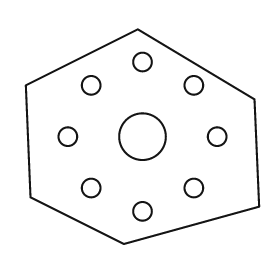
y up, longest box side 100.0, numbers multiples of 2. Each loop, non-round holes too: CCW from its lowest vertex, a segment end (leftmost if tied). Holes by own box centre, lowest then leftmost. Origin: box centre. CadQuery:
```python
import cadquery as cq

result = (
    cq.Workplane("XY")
    .moveTo(-8.0, -46.0)
    .lineTo(50.0, -30.0)
    .lineTo(48.0, 16.0)
    .lineTo(-2.0, 46.0)
    .lineTo(-50.0, 22.0)
    .lineTo(-48.0, -26.0)
    .close()
    .moveTo(0.0, -32.0)
    .circle(4.0)
    .moveTo(-22.0, -22.0)
    .circle(4.0)
    .moveTo(22.0, -22.0)
    .circle(4.0)
    .moveTo(-32.0, 0.0)
    .circle(4.0)
    .moveTo(0.0, 0.0)
    .circle(10.0)
    .moveTo(32.0, 0.0)
    .circle(4.0)
    .moveTo(-22.0, 22.0)
    .circle(4.0)
    .moveTo(22.0, 22.0)
    .circle(4.0)
    .moveTo(0.0, 32.0)
    .circle(4.0)
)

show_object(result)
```